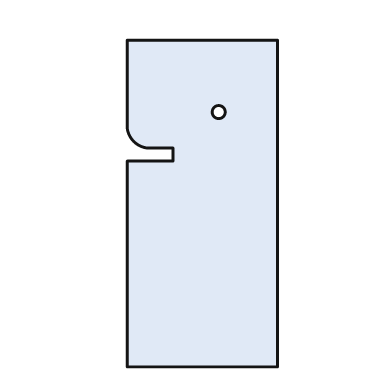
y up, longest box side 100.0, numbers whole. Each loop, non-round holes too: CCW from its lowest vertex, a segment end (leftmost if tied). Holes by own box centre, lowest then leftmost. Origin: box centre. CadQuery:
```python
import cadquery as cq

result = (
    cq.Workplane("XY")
    .moveTo(-23.0, -50.0)
    .lineTo(23.0, -50.0)
    .lineTo(23.0, 50.0)
    .lineTo(-23.0, 50.0)
    .lineTo(-23.0, 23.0)
    .threePointArc((-21.0, 19.0), (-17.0, 17.0))
    .lineTo(-9.0, 17.0)
    .lineTo(-9.0, 13.0)
    .lineTo(-23.0, 13.0)
    .close()
    .moveTo(5.0, 28.0)
    .circle(2.0)
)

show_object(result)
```